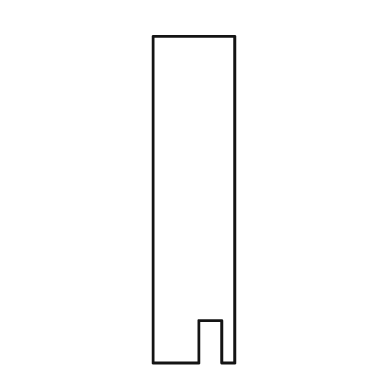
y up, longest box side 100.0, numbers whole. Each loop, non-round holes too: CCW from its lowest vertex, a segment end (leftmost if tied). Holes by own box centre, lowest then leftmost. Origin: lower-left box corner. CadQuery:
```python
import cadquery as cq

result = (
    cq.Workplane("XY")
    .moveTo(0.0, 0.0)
    .lineTo(14.0, 0.0)
    .lineTo(14.0, 13.0)
    .lineTo(21.0, 13.0)
    .lineTo(21.0, 0.0)
    .lineTo(25.0, 0.0)
    .lineTo(25.0, 100.0)
    .lineTo(0.0, 100.0)
    .close()
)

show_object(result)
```